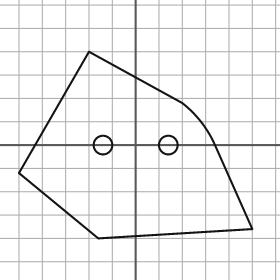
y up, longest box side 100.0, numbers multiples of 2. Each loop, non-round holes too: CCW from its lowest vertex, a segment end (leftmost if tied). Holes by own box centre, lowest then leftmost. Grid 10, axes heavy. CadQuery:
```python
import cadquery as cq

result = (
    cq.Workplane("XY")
    .moveTo(-16.0, -40.0)
    .lineTo(50.0, -36.0)
    .lineTo(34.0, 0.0)
    .threePointArc((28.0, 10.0), (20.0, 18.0))
    .lineTo(-20.0, 40.0)
    .lineTo(-50.0, -12.0)
    .close()
    .moveTo(-14.0, 0.0)
    .circle(4.0)
    .moveTo(14.0, 0.0)
    .circle(4.0)
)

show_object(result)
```